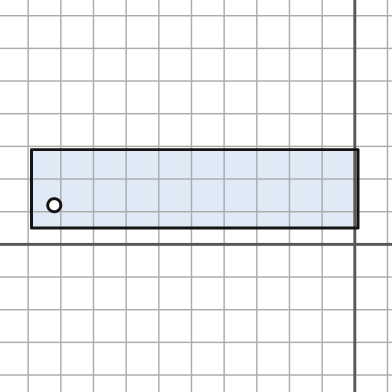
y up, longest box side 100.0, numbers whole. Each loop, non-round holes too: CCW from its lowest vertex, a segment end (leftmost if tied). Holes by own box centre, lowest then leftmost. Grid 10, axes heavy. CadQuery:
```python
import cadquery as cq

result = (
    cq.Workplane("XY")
    .moveTo(-99.0, 5.0)
    .lineTo(1.0, 5.0)
    .lineTo(1.0, 29.0)
    .lineTo(-99.0, 29.0)
    .close()
    .moveTo(-92.0, 12.0)
    .circle(2.0)
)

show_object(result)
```